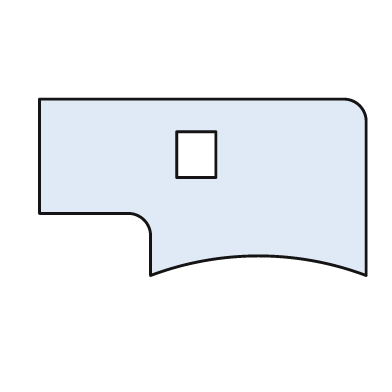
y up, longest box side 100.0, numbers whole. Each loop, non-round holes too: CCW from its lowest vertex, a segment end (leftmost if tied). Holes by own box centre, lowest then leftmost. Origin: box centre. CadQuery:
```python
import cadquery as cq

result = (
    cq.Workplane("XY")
    .moveTo(-16.0, -27.0)
    .threePointArc((17.0, -21.0), (50.0, -27.0))
    .lineTo(50.0, 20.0)
    .threePointArc((48.0, 25.0), (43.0, 27.0))
    .lineTo(-50.0, 27.0)
    .lineTo(-50.0, -8.0)
    .lineTo(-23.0, -8.0)
    .threePointArc((-18.0, -10.0), (-16.0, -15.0))
    .close()
    .moveTo(-8.0, 3.0)
    .lineTo(4.0, 3.0)
    .lineTo(4.0, 17.0)
    .lineTo(-8.0, 17.0)
    .close()
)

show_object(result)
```